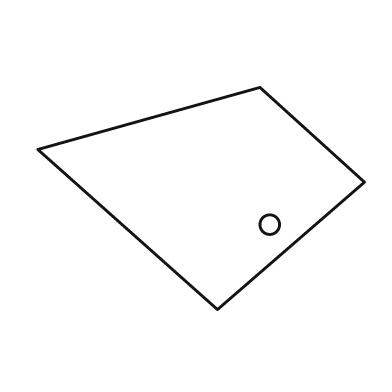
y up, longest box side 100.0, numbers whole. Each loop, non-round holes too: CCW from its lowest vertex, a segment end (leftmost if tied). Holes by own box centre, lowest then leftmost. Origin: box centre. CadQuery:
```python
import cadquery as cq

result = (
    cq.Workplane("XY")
    .moveTo(5.0, -34.0)
    .lineTo(50.0, 5.0)
    .lineTo(18.0, 34.0)
    .lineTo(-50.0, 15.0)
    .close()
    .moveTo(21.0, -8.0)
    .circle(3.0)
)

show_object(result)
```